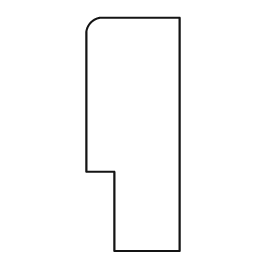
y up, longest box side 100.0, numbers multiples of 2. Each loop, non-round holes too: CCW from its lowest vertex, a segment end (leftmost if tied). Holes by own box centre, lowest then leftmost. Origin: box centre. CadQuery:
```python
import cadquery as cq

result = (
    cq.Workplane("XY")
    .moveTo(-8.0, -50.0)
    .lineTo(20.0, -50.0)
    .lineTo(20.0, 50.0)
    .lineTo(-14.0, 50.0)
    .threePointArc((-18.0, 48.0), (-20.0, 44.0))
    .lineTo(-20.0, -16.0)
    .lineTo(-8.0, -16.0)
    .close()
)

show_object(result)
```